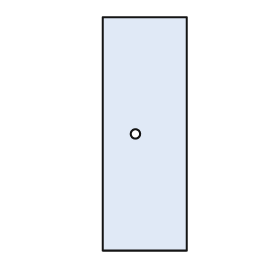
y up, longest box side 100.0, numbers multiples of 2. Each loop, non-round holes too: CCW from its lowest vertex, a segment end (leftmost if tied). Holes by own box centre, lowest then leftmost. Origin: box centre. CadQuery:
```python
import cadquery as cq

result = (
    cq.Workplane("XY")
    .moveTo(-18.0, -50.0)
    .lineTo(18.0, -50.0)
    .lineTo(18.0, 50.0)
    .lineTo(-18.0, 50.0)
    .close()
    .moveTo(-4.0, 0.0)
    .circle(2.0)
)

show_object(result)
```